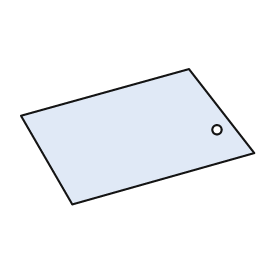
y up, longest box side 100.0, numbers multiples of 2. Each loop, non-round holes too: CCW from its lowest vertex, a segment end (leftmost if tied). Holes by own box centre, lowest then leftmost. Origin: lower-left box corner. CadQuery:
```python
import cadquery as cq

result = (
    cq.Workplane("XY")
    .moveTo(22.0, 0.0)
    .lineTo(100.0, 22.0)
    .lineTo(72.0, 58.0)
    .lineTo(0.0, 38.0)
    .close()
    .moveTo(84.0, 32.0)
    .circle(2.0)
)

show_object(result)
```